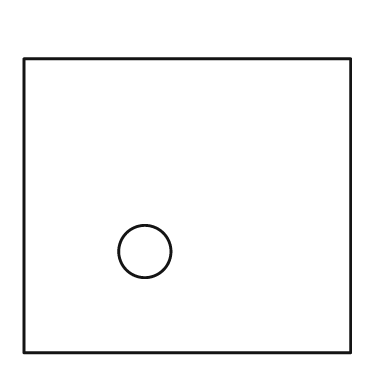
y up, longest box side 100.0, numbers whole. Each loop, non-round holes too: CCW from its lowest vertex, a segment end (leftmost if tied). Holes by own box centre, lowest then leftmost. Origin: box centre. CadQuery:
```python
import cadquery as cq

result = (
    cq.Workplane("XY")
    .moveTo(-50.0, -45.0)
    .lineTo(50.0, -45.0)
    .lineTo(50.0, 45.0)
    .lineTo(-50.0, 45.0)
    .close()
    .moveTo(-13.0, -14.0)
    .circle(8.0)
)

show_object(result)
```